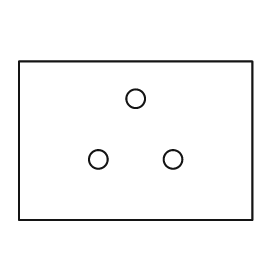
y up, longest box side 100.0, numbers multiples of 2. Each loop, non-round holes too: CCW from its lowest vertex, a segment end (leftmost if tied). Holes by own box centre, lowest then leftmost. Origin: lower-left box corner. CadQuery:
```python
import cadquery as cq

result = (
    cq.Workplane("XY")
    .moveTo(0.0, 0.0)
    .lineTo(100.0, 0.0)
    .lineTo(100.0, 68.0)
    .lineTo(0.0, 68.0)
    .close()
    .moveTo(34.0, 26.0)
    .circle(4.0)
    .moveTo(66.0, 26.0)
    .circle(4.0)
    .moveTo(50.0, 52.0)
    .circle(4.0)
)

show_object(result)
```